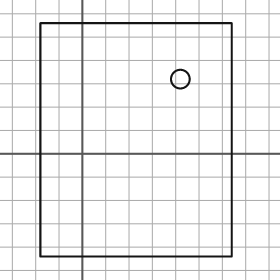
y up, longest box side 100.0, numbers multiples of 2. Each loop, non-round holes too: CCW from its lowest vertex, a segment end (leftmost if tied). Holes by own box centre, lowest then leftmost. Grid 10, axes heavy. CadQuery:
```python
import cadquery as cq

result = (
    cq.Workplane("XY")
    .moveTo(-18.0, -44.0)
    .lineTo(64.0, -44.0)
    .lineTo(64.0, 56.0)
    .lineTo(-18.0, 56.0)
    .close()
    .moveTo(42.0, 32.0)
    .circle(4.0)
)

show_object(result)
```